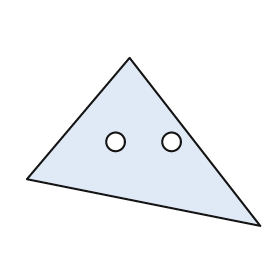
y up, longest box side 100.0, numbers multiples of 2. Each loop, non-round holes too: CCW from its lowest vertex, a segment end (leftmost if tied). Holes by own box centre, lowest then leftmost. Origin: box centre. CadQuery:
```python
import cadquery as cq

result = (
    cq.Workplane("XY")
    .moveTo(50.0, -36.0)
    .lineTo(-6.0, 36.0)
    .lineTo(-50.0, -16.0)
    .close()
    .moveTo(-12.0, 0.0)
    .circle(4.0)
    .moveTo(12.0, 0.0)
    .circle(4.0)
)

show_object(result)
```